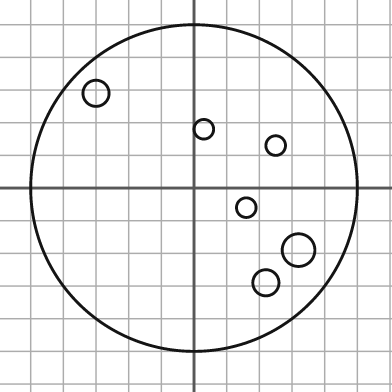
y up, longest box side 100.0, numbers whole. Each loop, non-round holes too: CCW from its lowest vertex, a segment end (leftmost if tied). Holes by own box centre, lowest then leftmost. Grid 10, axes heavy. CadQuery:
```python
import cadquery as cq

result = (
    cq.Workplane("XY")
    .moveTo(0.0, 0.0)
    .circle(50.0)
    .moveTo(22.0, -29.0)
    .circle(4.0)
    .moveTo(32.0, -19.0)
    .circle(5.0)
    .moveTo(16.0, -6.0)
    .circle(3.0)
    .moveTo(25.0, 13.0)
    .circle(3.0)
    .moveTo(3.0, 18.0)
    .circle(3.0)
    .moveTo(-30.0, 29.0)
    .circle(4.0)
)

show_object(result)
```